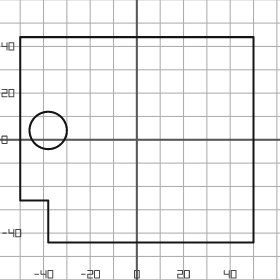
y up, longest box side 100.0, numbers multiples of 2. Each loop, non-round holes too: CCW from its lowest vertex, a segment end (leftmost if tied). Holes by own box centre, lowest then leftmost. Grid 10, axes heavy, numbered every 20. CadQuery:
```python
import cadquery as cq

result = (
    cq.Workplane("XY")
    .moveTo(-38.0, -44.0)
    .lineTo(50.0, -44.0)
    .lineTo(50.0, 44.0)
    .lineTo(-50.0, 44.0)
    .lineTo(-50.0, -26.0)
    .lineTo(-38.0, -26.0)
    .close()
    .moveTo(-38.0, 4.0)
    .circle(8.0)
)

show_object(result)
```